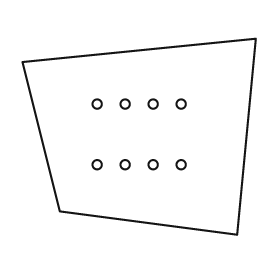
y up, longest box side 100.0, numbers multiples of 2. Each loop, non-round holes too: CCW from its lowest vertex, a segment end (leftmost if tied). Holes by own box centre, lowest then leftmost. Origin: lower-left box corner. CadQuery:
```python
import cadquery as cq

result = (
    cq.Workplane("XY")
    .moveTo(92.0, 0.0)
    .lineTo(100.0, 84.0)
    .lineTo(0.0, 74.0)
    .lineTo(16.0, 10.0)
    .close()
    .moveTo(32.0, 30.0)
    .circle(2.0)
    .moveTo(44.0, 30.0)
    .circle(2.0)
    .moveTo(56.0, 30.0)
    .circle(2.0)
    .moveTo(68.0, 30.0)
    .circle(2.0)
    .moveTo(32.0, 56.0)
    .circle(2.0)
    .moveTo(44.0, 56.0)
    .circle(2.0)
    .moveTo(56.0, 56.0)
    .circle(2.0)
    .moveTo(68.0, 56.0)
    .circle(2.0)
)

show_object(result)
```